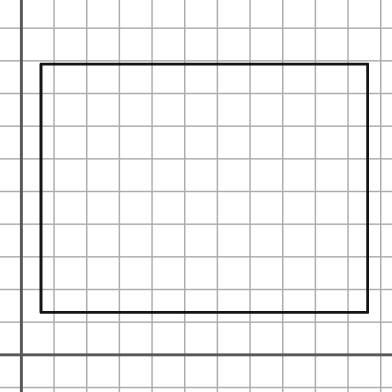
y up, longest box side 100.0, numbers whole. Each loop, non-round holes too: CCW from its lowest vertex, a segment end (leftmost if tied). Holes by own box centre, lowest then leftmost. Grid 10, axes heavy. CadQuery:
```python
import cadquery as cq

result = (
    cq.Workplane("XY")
    .moveTo(6.0, 13.0)
    .lineTo(106.0, 13.0)
    .lineTo(106.0, 89.0)
    .lineTo(6.0, 89.0)
    .close()
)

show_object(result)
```